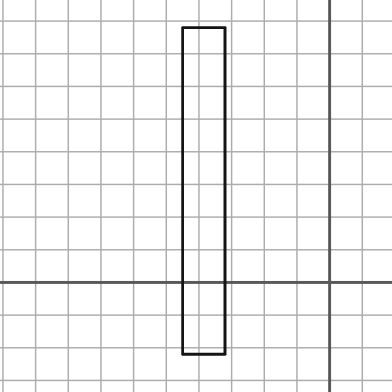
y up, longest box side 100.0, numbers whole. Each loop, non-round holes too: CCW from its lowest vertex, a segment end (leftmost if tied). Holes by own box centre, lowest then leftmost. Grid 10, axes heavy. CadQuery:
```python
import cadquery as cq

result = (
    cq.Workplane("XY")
    .moveTo(-45.0, -22.0)
    .lineTo(-32.0, -22.0)
    .lineTo(-32.0, 78.0)
    .lineTo(-45.0, 78.0)
    .close()
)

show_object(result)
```